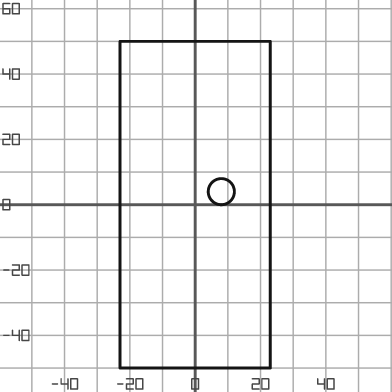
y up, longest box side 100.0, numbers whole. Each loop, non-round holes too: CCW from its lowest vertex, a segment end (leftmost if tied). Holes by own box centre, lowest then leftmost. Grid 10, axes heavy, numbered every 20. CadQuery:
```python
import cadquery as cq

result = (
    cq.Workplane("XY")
    .moveTo(-23.0, -50.0)
    .lineTo(23.0, -50.0)
    .lineTo(23.0, 50.0)
    .lineTo(-23.0, 50.0)
    .close()
    .moveTo(8.0, 4.0)
    .circle(4.0)
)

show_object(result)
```